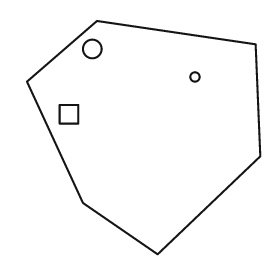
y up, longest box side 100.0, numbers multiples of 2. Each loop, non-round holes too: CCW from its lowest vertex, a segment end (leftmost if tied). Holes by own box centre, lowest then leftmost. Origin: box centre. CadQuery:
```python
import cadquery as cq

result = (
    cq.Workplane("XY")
    .moveTo(6.0, -50.0)
    .lineTo(50.0, -8.0)
    .lineTo(48.0, 40.0)
    .lineTo(-20.0, 50.0)
    .lineTo(-50.0, 24.0)
    .lineTo(-26.0, -28.0)
    .close()
    .moveTo(-36.0, 6.0)
    .lineTo(-28.0, 6.0)
    .lineTo(-28.0, 14.0)
    .lineTo(-36.0, 14.0)
    .close()
    .moveTo(22.0, 26.0)
    .circle(2.0)
    .moveTo(-22.0, 38.0)
    .circle(4.0)
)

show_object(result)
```